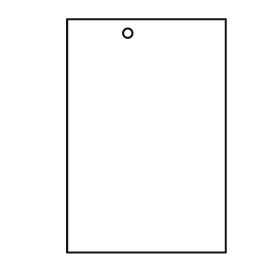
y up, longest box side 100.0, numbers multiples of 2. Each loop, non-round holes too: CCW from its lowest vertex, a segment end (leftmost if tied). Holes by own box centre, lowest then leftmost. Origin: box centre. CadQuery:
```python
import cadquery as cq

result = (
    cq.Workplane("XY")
    .moveTo(-34.0, -50.0)
    .lineTo(34.0, -50.0)
    .lineTo(34.0, 50.0)
    .lineTo(-34.0, 50.0)
    .close()
    .moveTo(-8.0, 44.0)
    .circle(2.0)
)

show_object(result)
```